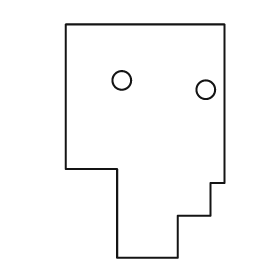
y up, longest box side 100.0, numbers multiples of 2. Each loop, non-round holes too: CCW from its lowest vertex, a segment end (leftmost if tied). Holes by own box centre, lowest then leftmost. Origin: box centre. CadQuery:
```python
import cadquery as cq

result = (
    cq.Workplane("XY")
    .moveTo(-12.0, -50.0)
    .lineTo(14.0, -50.0)
    .lineTo(14.0, -32.0)
    .lineTo(28.0, -32.0)
    .lineTo(28.0, -18.0)
    .lineTo(34.0, -18.0)
    .lineTo(34.0, 50.0)
    .lineTo(-34.0, 50.0)
    .lineTo(-34.0, -12.0)
    .lineTo(-12.0, -12.0)
    .close()
    .moveTo(26.0, 22.0)
    .circle(4.0)
    .moveTo(-10.0, 26.0)
    .circle(4.0)
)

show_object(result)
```